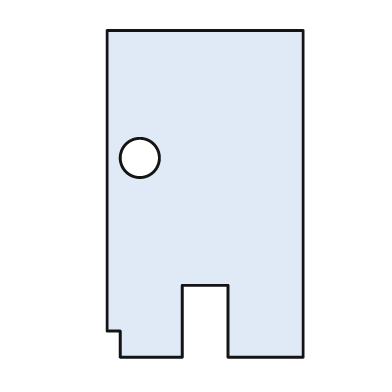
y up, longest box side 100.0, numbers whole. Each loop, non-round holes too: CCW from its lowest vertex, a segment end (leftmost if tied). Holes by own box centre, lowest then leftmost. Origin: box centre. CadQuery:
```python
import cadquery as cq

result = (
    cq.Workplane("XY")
    .moveTo(-26.0, -50.0)
    .lineTo(-7.0, -50.0)
    .lineTo(-7.0, -28.0)
    .lineTo(7.0, -28.0)
    .lineTo(7.0, -50.0)
    .lineTo(30.0, -50.0)
    .lineTo(30.0, 50.0)
    .lineTo(-30.0, 50.0)
    .lineTo(-30.0, -42.0)
    .lineTo(-26.0, -42.0)
    .close()
    .moveTo(-20.0, 11.0)
    .circle(6.0)
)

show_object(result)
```